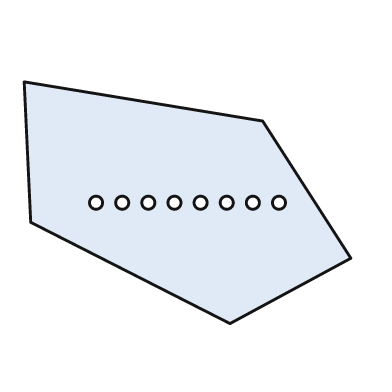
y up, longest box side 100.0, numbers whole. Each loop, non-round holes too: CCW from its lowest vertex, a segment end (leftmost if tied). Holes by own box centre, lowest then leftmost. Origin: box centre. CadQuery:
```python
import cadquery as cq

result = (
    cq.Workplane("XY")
    .moveTo(13.0, -37.0)
    .lineTo(50.0, -17.0)
    .lineTo(23.0, 25.0)
    .lineTo(-50.0, 37.0)
    .lineTo(-48.0, -6.0)
    .close()
    .moveTo(-28.0, 0.0)
    .circle(2.0)
    .moveTo(-20.0, 0.0)
    .circle(2.0)
    .moveTo(-12.0, 0.0)
    .circle(2.0)
    .moveTo(-4.0, 0.0)
    .circle(2.0)
    .moveTo(4.0, 0.0)
    .circle(2.0)
    .moveTo(12.0, 0.0)
    .circle(2.0)
    .moveTo(20.0, 0.0)
    .circle(2.0)
    .moveTo(28.0, 0.0)
    .circle(2.0)
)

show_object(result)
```